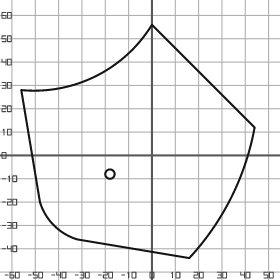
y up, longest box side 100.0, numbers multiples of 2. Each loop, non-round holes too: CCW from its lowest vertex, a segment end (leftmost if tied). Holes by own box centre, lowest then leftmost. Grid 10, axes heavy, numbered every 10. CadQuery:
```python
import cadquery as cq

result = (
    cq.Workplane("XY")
    .moveTo(16.0, -44.0)
    .threePointArc((34.0, -18.0), (44.0, 12.0))
    .lineTo(0.0, 56.0)
    .threePointArc((-24.0, 34.0), (-56.0, 28.0))
    .lineTo(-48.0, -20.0)
    .threePointArc((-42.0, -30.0), (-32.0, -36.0))
    .close()
    .moveTo(-18.0, -8.0)
    .circle(2.0)
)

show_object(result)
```